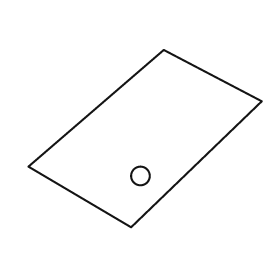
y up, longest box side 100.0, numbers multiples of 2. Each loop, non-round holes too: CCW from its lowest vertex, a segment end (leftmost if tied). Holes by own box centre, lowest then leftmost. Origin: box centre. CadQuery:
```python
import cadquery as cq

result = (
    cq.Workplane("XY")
    .moveTo(-6.0, -38.0)
    .lineTo(50.0, 16.0)
    .lineTo(8.0, 38.0)
    .lineTo(-50.0, -12.0)
    .close()
    .moveTo(-2.0, -16.0)
    .circle(4.0)
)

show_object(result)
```